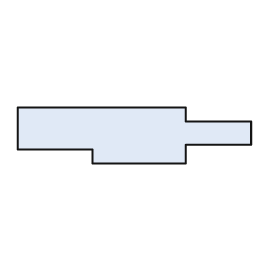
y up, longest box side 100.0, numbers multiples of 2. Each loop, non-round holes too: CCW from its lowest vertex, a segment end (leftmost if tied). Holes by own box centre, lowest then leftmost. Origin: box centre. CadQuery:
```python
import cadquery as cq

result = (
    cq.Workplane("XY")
    .moveTo(-18.0, -12.0)
    .lineTo(22.0, -12.0)
    .lineTo(22.0, -4.0)
    .lineTo(50.0, -4.0)
    .lineTo(50.0, 6.0)
    .lineTo(22.0, 6.0)
    .lineTo(22.0, 12.0)
    .lineTo(-50.0, 12.0)
    .lineTo(-50.0, -6.0)
    .lineTo(-18.0, -6.0)
    .close()
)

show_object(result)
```